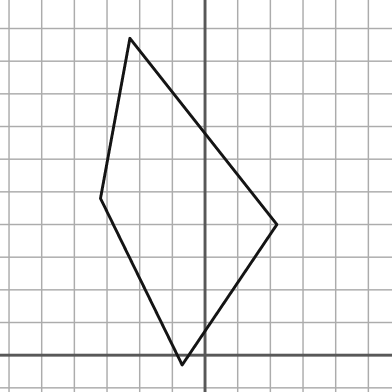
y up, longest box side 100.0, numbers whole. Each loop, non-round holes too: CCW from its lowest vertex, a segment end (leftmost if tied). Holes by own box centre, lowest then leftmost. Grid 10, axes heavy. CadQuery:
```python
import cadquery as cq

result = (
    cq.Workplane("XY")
    .moveTo(-7.0, -3.0)
    .lineTo(22.0, 40.0)
    .lineTo(-23.0, 97.0)
    .lineTo(-32.0, 48.0)
    .close()
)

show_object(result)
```